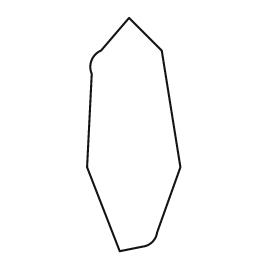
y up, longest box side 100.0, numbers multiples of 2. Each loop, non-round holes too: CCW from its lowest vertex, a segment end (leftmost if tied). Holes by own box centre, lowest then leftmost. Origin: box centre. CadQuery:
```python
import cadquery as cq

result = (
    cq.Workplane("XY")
    .moveTo(-6.0, -50.0)
    .lineTo(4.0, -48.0)
    .threePointArc((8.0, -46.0), (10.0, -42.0))
    .lineTo(20.0, -14.0)
    .lineTo(12.0, 36.0)
    .lineTo(-2.0, 50.0)
    .lineTo(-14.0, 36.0)
    .threePointArc((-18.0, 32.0), (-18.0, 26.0))
    .lineTo(-20.0, -14.0)
    .close()
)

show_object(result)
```